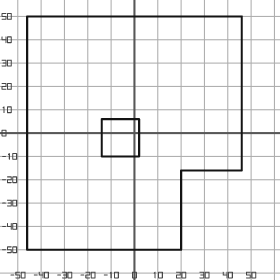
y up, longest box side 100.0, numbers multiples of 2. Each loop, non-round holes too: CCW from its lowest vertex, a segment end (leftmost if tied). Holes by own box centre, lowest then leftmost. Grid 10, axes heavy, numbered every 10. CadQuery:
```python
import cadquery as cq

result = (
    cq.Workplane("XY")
    .moveTo(-46.0, -50.0)
    .lineTo(20.0, -50.0)
    .lineTo(20.0, -16.0)
    .lineTo(46.0, -16.0)
    .lineTo(46.0, 50.0)
    .lineTo(-46.0, 50.0)
    .close()
    .moveTo(-14.0, -10.0)
    .lineTo(2.0, -10.0)
    .lineTo(2.0, 6.0)
    .lineTo(-14.0, 6.0)
    .close()
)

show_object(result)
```